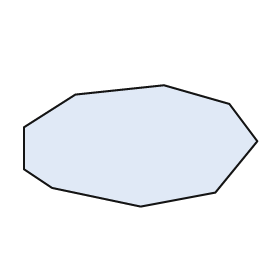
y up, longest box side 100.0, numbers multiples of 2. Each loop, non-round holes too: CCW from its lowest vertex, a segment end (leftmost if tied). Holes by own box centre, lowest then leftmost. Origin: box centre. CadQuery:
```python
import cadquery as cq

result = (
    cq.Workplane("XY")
    .moveTo(0.0, -26.0)
    .lineTo(32.0, -20.0)
    .lineTo(50.0, 2.0)
    .lineTo(38.0, 18.0)
    .lineTo(10.0, 26.0)
    .lineTo(-28.0, 22.0)
    .lineTo(-50.0, 8.0)
    .lineTo(-50.0, -10.0)
    .lineTo(-38.0, -18.0)
    .close()
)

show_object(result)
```